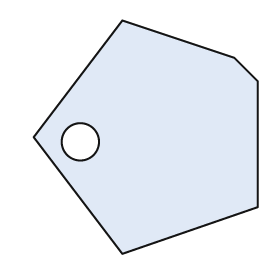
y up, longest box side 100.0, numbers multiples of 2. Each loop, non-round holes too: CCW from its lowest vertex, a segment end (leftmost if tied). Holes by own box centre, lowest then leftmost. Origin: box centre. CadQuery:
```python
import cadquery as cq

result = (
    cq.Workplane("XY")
    .moveTo(-10.0, -50.0)
    .lineTo(48.0, -30.0)
    .lineTo(48.0, 24.0)
    .lineTo(38.0, 34.0)
    .lineTo(-10.0, 50.0)
    .lineTo(-48.0, 0.0)
    .close()
    .moveTo(-28.0, -2.0)
    .circle(8.0)
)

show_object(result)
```